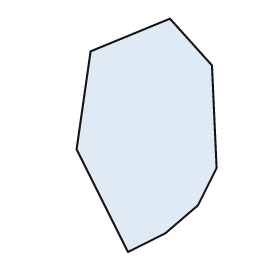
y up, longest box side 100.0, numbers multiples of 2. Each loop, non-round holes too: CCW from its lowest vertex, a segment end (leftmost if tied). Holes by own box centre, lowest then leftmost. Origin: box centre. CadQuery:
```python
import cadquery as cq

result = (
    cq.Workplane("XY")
    .moveTo(-8.0, -50.0)
    .lineTo(8.0, -42.0)
    .lineTo(22.0, -30.0)
    .lineTo(30.0, -14.0)
    .lineTo(28.0, 30.0)
    .lineTo(10.0, 50.0)
    .lineTo(-24.0, 36.0)
    .lineTo(-30.0, -6.0)
    .close()
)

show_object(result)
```